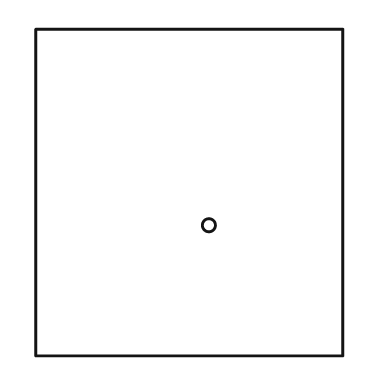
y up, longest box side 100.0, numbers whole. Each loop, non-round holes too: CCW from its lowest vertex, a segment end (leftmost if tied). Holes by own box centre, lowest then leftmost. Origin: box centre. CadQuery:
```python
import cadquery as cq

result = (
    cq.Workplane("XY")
    .moveTo(-47.0, -50.0)
    .lineTo(47.0, -50.0)
    .lineTo(47.0, 50.0)
    .lineTo(-47.0, 50.0)
    .close()
    .moveTo(6.0, -10.0)
    .circle(2.0)
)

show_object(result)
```